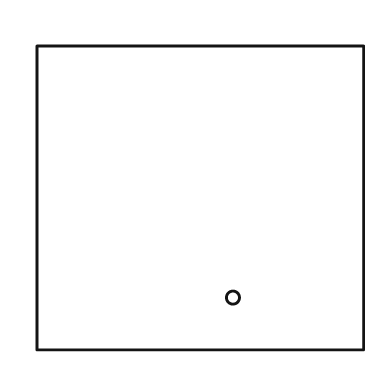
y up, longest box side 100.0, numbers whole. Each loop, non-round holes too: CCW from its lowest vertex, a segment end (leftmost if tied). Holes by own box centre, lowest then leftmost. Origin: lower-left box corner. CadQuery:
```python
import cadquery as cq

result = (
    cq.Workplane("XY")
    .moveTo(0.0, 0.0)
    .lineTo(100.0, 0.0)
    .lineTo(100.0, 93.0)
    .lineTo(0.0, 93.0)
    .close()
    .moveTo(60.0, 16.0)
    .circle(2.0)
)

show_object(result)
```